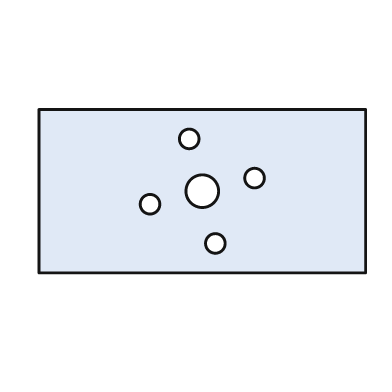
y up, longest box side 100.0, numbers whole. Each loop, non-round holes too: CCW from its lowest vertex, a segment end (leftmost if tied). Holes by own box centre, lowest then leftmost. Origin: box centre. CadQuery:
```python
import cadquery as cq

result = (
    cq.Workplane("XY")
    .moveTo(-50.0, -25.0)
    .lineTo(50.0, -25.0)
    .lineTo(50.0, 25.0)
    .lineTo(-50.0, 25.0)
    .close()
    .moveTo(4.0, -16.0)
    .circle(3.0)
    .moveTo(-16.0, -4.0)
    .circle(3.0)
    .moveTo(0.0, 0.0)
    .circle(5.0)
    .moveTo(16.0, 4.0)
    .circle(3.0)
    .moveTo(-4.0, 16.0)
    .circle(3.0)
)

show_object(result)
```